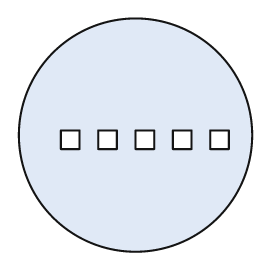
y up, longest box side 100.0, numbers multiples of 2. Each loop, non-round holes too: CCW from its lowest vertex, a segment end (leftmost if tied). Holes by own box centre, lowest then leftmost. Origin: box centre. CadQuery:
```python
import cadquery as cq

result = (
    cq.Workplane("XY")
    .moveTo(0.0, 0.0)
    .circle(50.0)
    .moveTo(-32.0, -6.0)
    .lineTo(-24.0, -6.0)
    .lineTo(-24.0, 2.0)
    .lineTo(-32.0, 2.0)
    .close()
    .moveTo(-16.0, -6.0)
    .lineTo(-8.0, -6.0)
    .lineTo(-8.0, 2.0)
    .lineTo(-16.0, 2.0)
    .close()
    .moveTo(0.0, -6.0)
    .lineTo(8.0, -6.0)
    .lineTo(8.0, 2.0)
    .lineTo(0.0, 2.0)
    .close()
    .moveTo(16.0, -6.0)
    .lineTo(24.0, -6.0)
    .lineTo(24.0, 2.0)
    .lineTo(16.0, 2.0)
    .close()
    .moveTo(32.0, -6.0)
    .lineTo(40.0, -6.0)
    .lineTo(40.0, 2.0)
    .lineTo(32.0, 2.0)
    .close()
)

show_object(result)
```